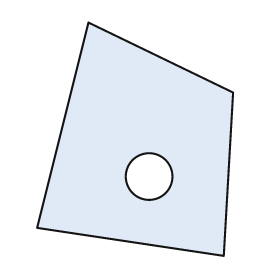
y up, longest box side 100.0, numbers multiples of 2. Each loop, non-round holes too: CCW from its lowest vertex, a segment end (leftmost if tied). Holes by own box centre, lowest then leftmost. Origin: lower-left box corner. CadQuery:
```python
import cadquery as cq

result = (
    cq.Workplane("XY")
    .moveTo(80.0, 0.0)
    .lineTo(84.0, 70.0)
    .lineTo(22.0, 100.0)
    .lineTo(0.0, 12.0)
    .close()
    .moveTo(48.0, 34.0)
    .circle(10.0)
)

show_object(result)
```